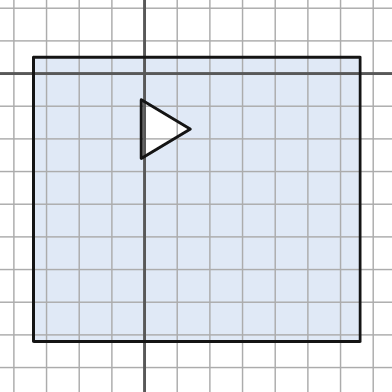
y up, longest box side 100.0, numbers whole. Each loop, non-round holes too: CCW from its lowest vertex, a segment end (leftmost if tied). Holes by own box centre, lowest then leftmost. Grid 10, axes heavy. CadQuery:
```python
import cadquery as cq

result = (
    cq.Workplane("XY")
    .moveTo(-34.0, -82.0)
    .lineTo(66.0, -82.0)
    .lineTo(66.0, 5.0)
    .lineTo(-34.0, 5.0)
    .close()
    .moveTo(-1.0, -26.0)
    .lineTo(14.0, -17.0)
    .lineTo(-1.0, -8.0)
    .close()
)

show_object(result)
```